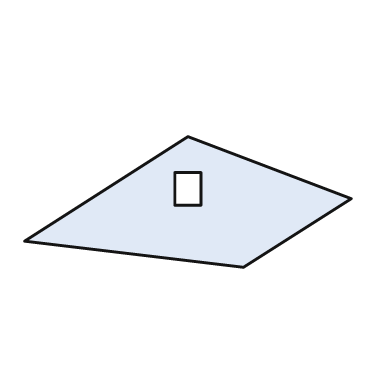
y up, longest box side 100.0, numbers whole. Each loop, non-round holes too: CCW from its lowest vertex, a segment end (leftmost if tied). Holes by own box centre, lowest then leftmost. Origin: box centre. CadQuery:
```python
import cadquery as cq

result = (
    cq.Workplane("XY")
    .moveTo(17.0, -20.0)
    .lineTo(50.0, 1.0)
    .lineTo(0.0, 20.0)
    .lineTo(-50.0, -12.0)
    .close()
    .moveTo(-4.0, -1.0)
    .lineTo(4.0, -1.0)
    .lineTo(4.0, 9.0)
    .lineTo(-4.0, 9.0)
    .close()
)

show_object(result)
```